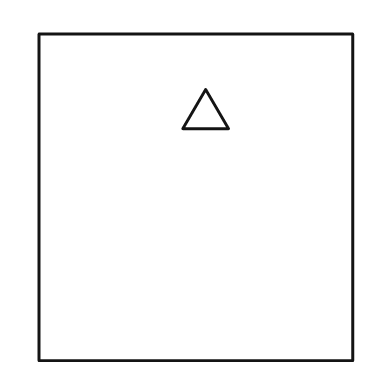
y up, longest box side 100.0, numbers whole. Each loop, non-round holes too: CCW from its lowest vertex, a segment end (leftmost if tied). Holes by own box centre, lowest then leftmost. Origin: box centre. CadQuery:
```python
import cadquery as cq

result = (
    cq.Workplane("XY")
    .moveTo(-48.0, -50.0)
    .lineTo(48.0, -50.0)
    .lineTo(48.0, 50.0)
    .lineTo(-48.0, 50.0)
    .close()
    .moveTo(-4.0, 21.0)
    .lineTo(10.0, 21.0)
    .lineTo(3.0, 33.0)
    .close()
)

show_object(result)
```